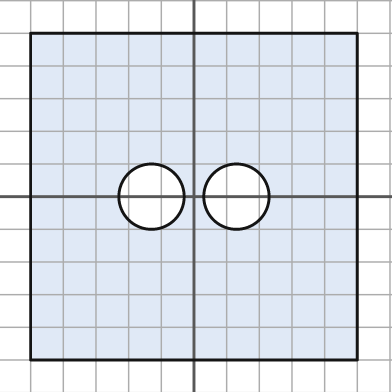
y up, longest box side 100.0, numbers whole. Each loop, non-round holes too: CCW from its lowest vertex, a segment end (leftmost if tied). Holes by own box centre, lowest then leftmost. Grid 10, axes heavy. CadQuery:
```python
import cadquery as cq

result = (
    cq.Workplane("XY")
    .moveTo(-50.0, -50.0)
    .lineTo(50.0, -50.0)
    .lineTo(50.0, 50.0)
    .lineTo(-50.0, 50.0)
    .close()
    .moveTo(-13.0, 0.0)
    .circle(10.0)
    .moveTo(13.0, 0.0)
    .circle(10.0)
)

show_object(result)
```